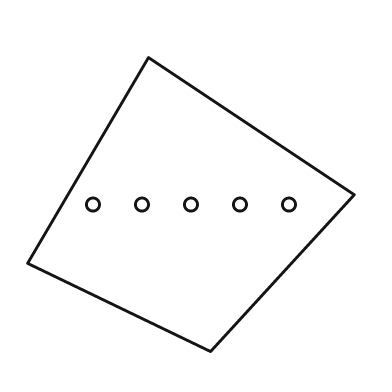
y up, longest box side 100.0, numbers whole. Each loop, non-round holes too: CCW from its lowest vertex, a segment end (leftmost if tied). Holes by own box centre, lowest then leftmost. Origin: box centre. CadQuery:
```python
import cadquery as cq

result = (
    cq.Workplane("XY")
    .moveTo(6.0, -45.0)
    .lineTo(50.0, 3.0)
    .lineTo(-13.0, 45.0)
    .lineTo(-50.0, -18.0)
    .close()
    .moveTo(-30.0, 0.0)
    .circle(2.0)
    .moveTo(-15.0, 0.0)
    .circle(2.0)
    .moveTo(0.0, 0.0)
    .circle(2.0)
    .moveTo(15.0, 0.0)
    .circle(2.0)
    .moveTo(30.0, 0.0)
    .circle(2.0)
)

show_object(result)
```